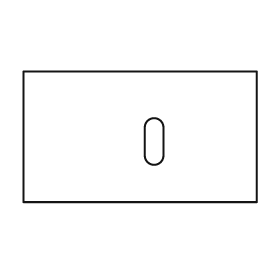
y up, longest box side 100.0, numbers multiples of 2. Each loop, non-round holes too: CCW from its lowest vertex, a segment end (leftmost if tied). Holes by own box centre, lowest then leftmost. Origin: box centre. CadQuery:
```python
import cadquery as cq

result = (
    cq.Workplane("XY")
    .moveTo(-50.0, -28.0)
    .lineTo(50.0, -28.0)
    .lineTo(50.0, 28.0)
    .lineTo(-50.0, 28.0)
    .close()
    .moveTo(2.0, -8.0)
    .threePointArc((6.0, -12.0), (10.0, -8.0))
    .lineTo(10.0, 4.0)
    .threePointArc((6.0, 8.0), (2.0, 4.0))
    .close()
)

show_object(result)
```